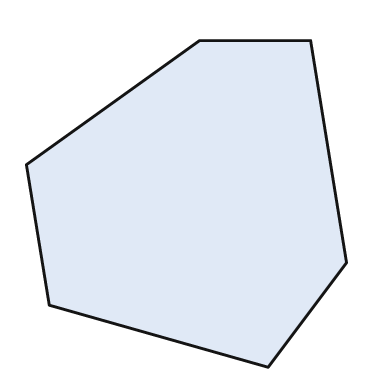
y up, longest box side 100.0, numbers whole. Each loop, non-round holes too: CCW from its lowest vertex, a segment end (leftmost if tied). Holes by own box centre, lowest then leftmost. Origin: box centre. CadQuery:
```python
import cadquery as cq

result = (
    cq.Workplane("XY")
    .moveTo(25.0, -50.0)
    .lineTo(49.0, -18.0)
    .lineTo(38.0, 50.0)
    .lineTo(4.0, 50.0)
    .lineTo(-49.0, 12.0)
    .lineTo(-42.0, -31.0)
    .close()
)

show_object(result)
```